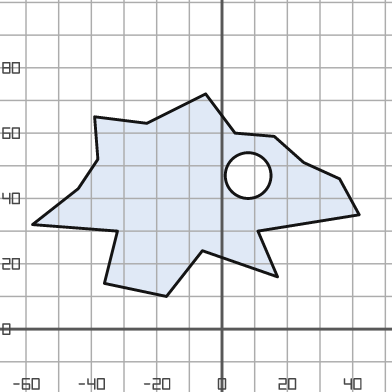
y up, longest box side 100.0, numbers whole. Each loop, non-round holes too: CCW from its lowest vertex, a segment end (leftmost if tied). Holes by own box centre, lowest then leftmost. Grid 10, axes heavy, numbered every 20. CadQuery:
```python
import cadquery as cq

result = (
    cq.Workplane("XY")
    .moveTo(-17.0, 10.0)
    .lineTo(-6.0, 24.0)
    .lineTo(17.0, 16.0)
    .lineTo(11.0, 30.0)
    .lineTo(42.0, 35.0)
    .lineTo(36.0, 46.0)
    .lineTo(25.0, 51.0)
    .lineTo(16.0, 59.0)
    .lineTo(4.0, 60.0)
    .lineTo(-5.0, 72.0)
    .lineTo(-23.0, 63.0)
    .lineTo(-39.0, 65.0)
    .lineTo(-38.0, 52.0)
    .lineTo(-44.0, 43.0)
    .lineTo(-58.0, 32.0)
    .lineTo(-32.0, 30.0)
    .lineTo(-36.0, 14.0)
    .close()
    .moveTo(8.0, 47.0)
    .circle(7.0)
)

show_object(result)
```